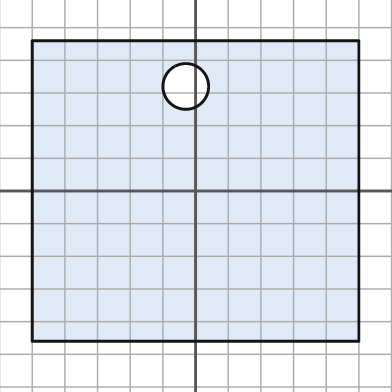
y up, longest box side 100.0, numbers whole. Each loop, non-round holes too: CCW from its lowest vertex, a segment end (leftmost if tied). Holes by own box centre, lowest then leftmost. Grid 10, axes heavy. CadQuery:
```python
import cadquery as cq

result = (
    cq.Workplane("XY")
    .moveTo(-50.0, -46.0)
    .lineTo(50.0, -46.0)
    .lineTo(50.0, 46.0)
    .lineTo(-50.0, 46.0)
    .close()
    .moveTo(-3.0, 32.0)
    .circle(7.0)
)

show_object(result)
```